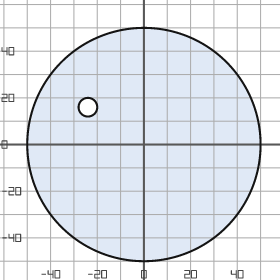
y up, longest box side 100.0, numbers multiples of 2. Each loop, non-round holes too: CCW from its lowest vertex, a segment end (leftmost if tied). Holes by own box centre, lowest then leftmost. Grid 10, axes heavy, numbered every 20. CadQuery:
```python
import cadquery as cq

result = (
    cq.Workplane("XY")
    .moveTo(0.0, 0.0)
    .circle(50.0)
    .moveTo(-24.0, 16.0)
    .circle(4.0)
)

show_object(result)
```